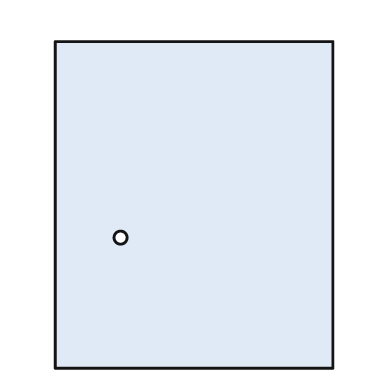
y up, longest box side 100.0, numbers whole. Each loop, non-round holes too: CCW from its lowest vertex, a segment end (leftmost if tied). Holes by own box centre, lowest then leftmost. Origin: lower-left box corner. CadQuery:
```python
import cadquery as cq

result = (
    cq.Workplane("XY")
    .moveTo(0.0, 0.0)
    .lineTo(85.0, 0.0)
    .lineTo(85.0, 100.0)
    .lineTo(0.0, 100.0)
    .close()
    .moveTo(20.0, 40.0)
    .circle(2.0)
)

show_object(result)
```